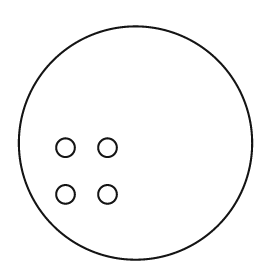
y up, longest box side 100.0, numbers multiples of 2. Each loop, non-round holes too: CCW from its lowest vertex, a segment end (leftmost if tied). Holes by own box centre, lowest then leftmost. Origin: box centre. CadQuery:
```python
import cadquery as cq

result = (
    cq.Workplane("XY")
    .moveTo(0.0, 0.0)
    .circle(50.0)
    .moveTo(-30.0, -22.0)
    .circle(4.0)
    .moveTo(-12.0, -22.0)
    .circle(4.0)
    .moveTo(-30.0, -2.0)
    .circle(4.0)
    .moveTo(-12.0, -2.0)
    .circle(4.0)
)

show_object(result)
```